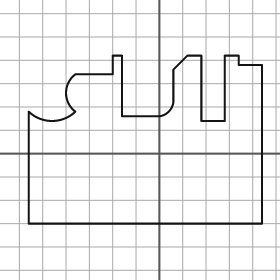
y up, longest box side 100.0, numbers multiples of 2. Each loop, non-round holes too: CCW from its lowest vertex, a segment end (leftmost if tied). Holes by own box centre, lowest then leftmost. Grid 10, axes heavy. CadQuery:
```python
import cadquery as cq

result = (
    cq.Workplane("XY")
    .moveTo(-56.0, -30.0)
    .lineTo(44.0, -30.0)
    .lineTo(44.0, 38.0)
    .lineTo(34.0, 38.0)
    .lineTo(34.0, 42.0)
    .lineTo(28.0, 42.0)
    .lineTo(28.0, 14.0)
    .lineTo(18.0, 14.0)
    .lineTo(18.0, 42.0)
    .lineTo(12.0, 42.0)
    .lineTo(6.0, 36.0)
    .lineTo(6.0, 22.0)
    .threePointArc((4.0, 18.0), (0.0, 16.0))
    .lineTo(-16.0, 16.0)
    .lineTo(-16.0, 42.0)
    .lineTo(-20.0, 42.0)
    .lineTo(-20.0, 34.0)
    .lineTo(-36.0, 34.0)
    .threePointArc((-40.0, 26.0), (-36.0, 18.0))
    .threePointArc((-46.0, 14.0), (-56.0, 18.0))
    .close()
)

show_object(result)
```